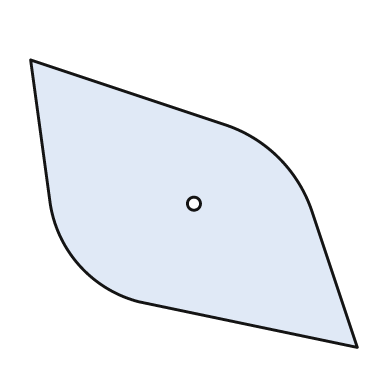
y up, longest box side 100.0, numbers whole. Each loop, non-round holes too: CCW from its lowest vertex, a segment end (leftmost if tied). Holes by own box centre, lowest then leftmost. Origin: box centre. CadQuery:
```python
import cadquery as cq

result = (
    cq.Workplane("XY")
    .moveTo(50.0, -44.0)
    .lineTo(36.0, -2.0)
    .threePointArc((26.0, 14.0), (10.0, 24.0))
    .lineTo(-50.0, 44.0)
    .lineTo(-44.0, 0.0)
    .threePointArc((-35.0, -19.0), (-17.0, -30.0))
    .close()
    .moveTo(0.0, 0.0)
    .circle(2.0)
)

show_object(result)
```